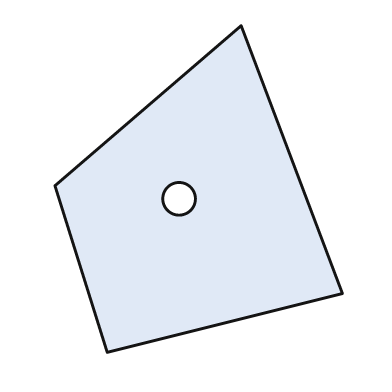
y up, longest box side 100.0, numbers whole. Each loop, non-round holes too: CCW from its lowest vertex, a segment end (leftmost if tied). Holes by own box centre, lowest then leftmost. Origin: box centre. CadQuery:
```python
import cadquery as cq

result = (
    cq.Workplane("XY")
    .moveTo(-28.0, -50.0)
    .lineTo(44.0, -32.0)
    .lineTo(13.0, 50.0)
    .lineTo(-44.0, 1.0)
    .close()
    .moveTo(-6.0, -3.0)
    .circle(5.0)
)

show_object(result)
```